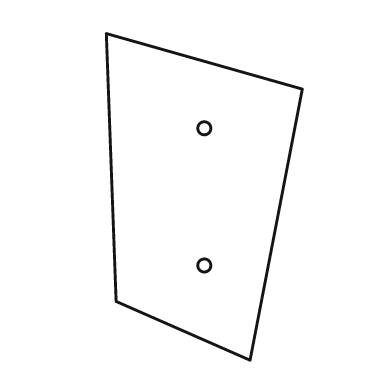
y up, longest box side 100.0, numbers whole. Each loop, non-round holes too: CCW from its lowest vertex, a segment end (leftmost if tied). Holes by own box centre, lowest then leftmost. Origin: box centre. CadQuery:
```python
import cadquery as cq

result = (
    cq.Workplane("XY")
    .moveTo(14.0, -50.0)
    .lineTo(30.0, 33.0)
    .lineTo(-30.0, 50.0)
    .lineTo(-27.0, -32.0)
    .close()
    .moveTo(0.0, -21.0)
    .circle(2.0)
    .moveTo(0.0, 21.0)
    .circle(2.0)
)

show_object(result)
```